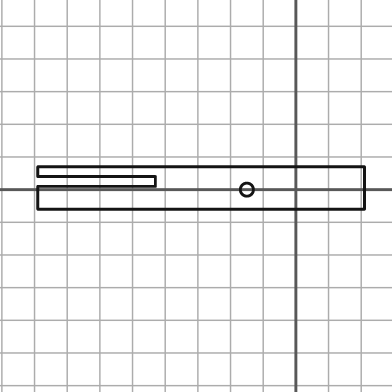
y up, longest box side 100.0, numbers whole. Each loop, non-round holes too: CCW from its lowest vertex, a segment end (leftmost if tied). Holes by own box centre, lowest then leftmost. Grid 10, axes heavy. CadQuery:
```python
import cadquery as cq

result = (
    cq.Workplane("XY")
    .moveTo(-79.0, -6.0)
    .lineTo(21.0, -6.0)
    .lineTo(21.0, 7.0)
    .lineTo(-79.0, 7.0)
    .lineTo(-79.0, 4.0)
    .lineTo(-43.0, 4.0)
    .lineTo(-43.0, 1.0)
    .lineTo(-79.0, 1.0)
    .close()
    .moveTo(-15.0, 0.0)
    .circle(2.0)
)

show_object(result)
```